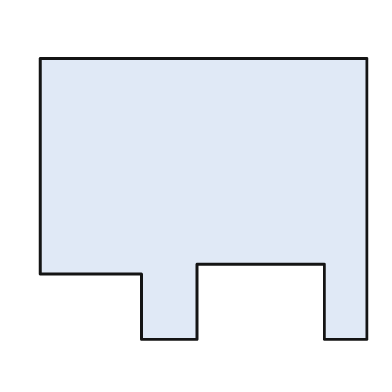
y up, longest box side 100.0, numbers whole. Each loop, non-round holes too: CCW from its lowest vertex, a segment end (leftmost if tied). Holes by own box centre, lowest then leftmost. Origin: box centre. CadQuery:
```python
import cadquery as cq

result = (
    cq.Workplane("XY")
    .moveTo(-19.0, -43.0)
    .lineTo(-2.0, -43.0)
    .lineTo(-2.0, -20.0)
    .lineTo(37.0, -20.0)
    .lineTo(37.0, -43.0)
    .lineTo(50.0, -43.0)
    .lineTo(50.0, 43.0)
    .lineTo(-50.0, 43.0)
    .lineTo(-50.0, -23.0)
    .lineTo(-19.0, -23.0)
    .close()
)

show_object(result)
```